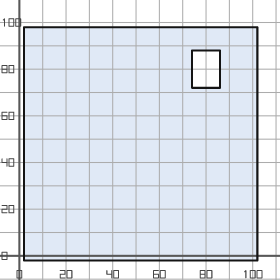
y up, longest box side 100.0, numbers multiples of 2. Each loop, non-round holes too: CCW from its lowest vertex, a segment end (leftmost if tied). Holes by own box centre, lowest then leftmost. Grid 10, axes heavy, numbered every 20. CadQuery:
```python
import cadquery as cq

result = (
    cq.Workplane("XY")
    .moveTo(2.0, -2.0)
    .lineTo(102.0, -2.0)
    .lineTo(102.0, 98.0)
    .lineTo(2.0, 98.0)
    .close()
    .moveTo(74.0, 72.0)
    .lineTo(86.0, 72.0)
    .lineTo(86.0, 88.0)
    .lineTo(74.0, 88.0)
    .close()
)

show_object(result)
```